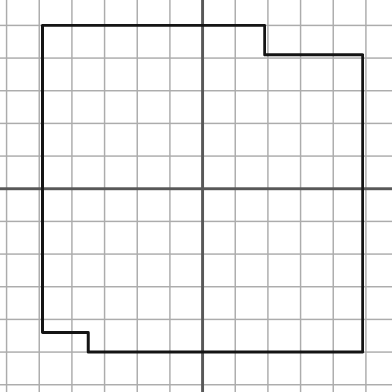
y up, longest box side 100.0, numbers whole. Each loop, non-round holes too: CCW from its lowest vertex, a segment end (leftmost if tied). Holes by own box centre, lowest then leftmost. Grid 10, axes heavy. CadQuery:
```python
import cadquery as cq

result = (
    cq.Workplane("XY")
    .moveTo(-35.0, -50.0)
    .lineTo(49.0, -50.0)
    .lineTo(49.0, 41.0)
    .lineTo(19.0, 41.0)
    .lineTo(19.0, 50.0)
    .lineTo(-49.0, 50.0)
    .lineTo(-49.0, -44.0)
    .lineTo(-35.0, -44.0)
    .close()
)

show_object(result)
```